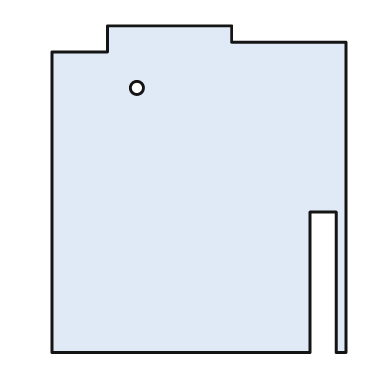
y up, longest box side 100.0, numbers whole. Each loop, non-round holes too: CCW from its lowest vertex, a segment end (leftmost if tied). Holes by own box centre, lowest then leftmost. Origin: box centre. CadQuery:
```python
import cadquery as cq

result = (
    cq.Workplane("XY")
    .moveTo(-45.0, -50.0)
    .lineTo(34.0, -50.0)
    .lineTo(34.0, -7.0)
    .lineTo(42.0, -7.0)
    .lineTo(42.0, -50.0)
    .lineTo(45.0, -50.0)
    .lineTo(45.0, 45.0)
    .lineTo(10.0, 45.0)
    .lineTo(10.0, 50.0)
    .lineTo(-28.0, 50.0)
    .lineTo(-28.0, 42.0)
    .lineTo(-45.0, 42.0)
    .close()
    .moveTo(-19.0, 31.0)
    .circle(2.0)
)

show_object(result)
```